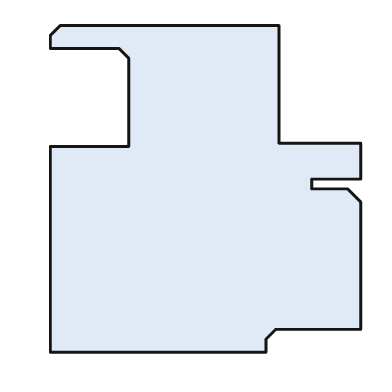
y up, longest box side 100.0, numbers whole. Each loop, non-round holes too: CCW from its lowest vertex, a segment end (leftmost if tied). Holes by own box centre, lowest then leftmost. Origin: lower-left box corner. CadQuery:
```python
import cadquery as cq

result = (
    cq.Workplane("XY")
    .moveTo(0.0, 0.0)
    .lineTo(66.0, 0.0)
    .lineTo(66.0, 4.0)
    .lineTo(69.0, 7.0)
    .lineTo(95.0, 7.0)
    .lineTo(95.0, 46.0)
    .lineTo(91.0, 50.0)
    .lineTo(80.0, 50.0)
    .lineTo(80.0, 53.0)
    .lineTo(95.0, 53.0)
    .lineTo(95.0, 64.0)
    .lineTo(70.0, 64.0)
    .lineTo(70.0, 100.0)
    .lineTo(3.0, 100.0)
    .lineTo(0.0, 97.0)
    .lineTo(0.0, 93.0)
    .lineTo(21.0, 93.0)
    .lineTo(24.0, 90.0)
    .lineTo(24.0, 63.0)
    .lineTo(0.0, 63.0)
    .close()
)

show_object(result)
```